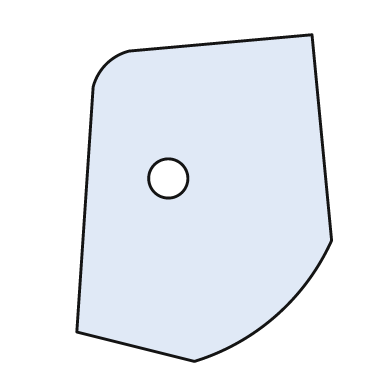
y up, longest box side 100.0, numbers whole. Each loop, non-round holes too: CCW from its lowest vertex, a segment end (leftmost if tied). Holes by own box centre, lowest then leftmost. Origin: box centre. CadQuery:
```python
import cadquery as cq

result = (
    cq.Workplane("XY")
    .moveTo(-3.0, -50.0)
    .threePointArc((22.0, -36.0), (39.0, -13.0))
    .lineTo(33.0, 50.0)
    .lineTo(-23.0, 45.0)
    .threePointArc((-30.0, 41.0), (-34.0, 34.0))
    .lineTo(-39.0, -41.0)
    .close()
    .moveTo(-11.0, 6.0)
    .circle(6.0)
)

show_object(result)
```